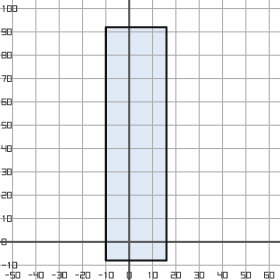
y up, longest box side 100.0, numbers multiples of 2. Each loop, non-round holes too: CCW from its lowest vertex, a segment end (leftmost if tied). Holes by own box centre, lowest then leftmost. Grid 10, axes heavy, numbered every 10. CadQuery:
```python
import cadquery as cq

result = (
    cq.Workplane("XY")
    .moveTo(-10.0, -8.0)
    .lineTo(16.0, -8.0)
    .lineTo(16.0, 92.0)
    .lineTo(-10.0, 92.0)
    .close()
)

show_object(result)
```